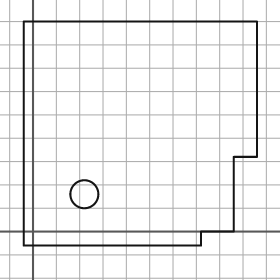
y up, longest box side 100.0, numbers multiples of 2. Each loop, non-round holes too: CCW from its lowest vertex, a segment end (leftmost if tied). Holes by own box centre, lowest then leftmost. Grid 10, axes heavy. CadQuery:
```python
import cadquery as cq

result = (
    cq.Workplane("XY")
    .moveTo(-4.0, -6.0)
    .lineTo(72.0, -6.0)
    .lineTo(72.0, 0.0)
    .lineTo(86.0, 0.0)
    .lineTo(86.0, 32.0)
    .lineTo(96.0, 32.0)
    .lineTo(96.0, 90.0)
    .lineTo(-4.0, 90.0)
    .close()
    .moveTo(22.0, 16.0)
    .circle(6.0)
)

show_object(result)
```